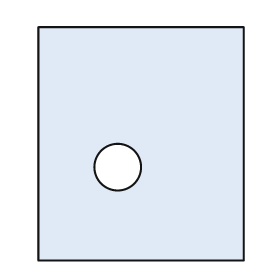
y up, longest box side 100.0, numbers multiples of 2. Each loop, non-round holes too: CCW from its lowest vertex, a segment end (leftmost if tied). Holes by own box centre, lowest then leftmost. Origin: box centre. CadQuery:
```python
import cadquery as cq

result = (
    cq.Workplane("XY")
    .moveTo(-44.0, -50.0)
    .lineTo(44.0, -50.0)
    .lineTo(44.0, 50.0)
    .lineTo(-44.0, 50.0)
    .close()
    .moveTo(-10.0, -10.0)
    .circle(10.0)
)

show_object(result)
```